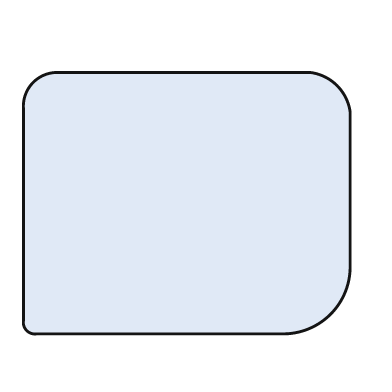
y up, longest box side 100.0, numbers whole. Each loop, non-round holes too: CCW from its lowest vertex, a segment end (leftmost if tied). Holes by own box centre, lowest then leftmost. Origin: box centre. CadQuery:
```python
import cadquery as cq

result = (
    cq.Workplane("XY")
    .moveTo(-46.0, -40.0)
    .lineTo(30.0, -40.0)
    .threePointArc((44.0, -34.0), (50.0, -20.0))
    .lineTo(50.0, 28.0)
    .threePointArc((46.0, 36.0), (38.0, 40.0))
    .lineTo(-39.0, 40.0)
    .threePointArc((-47.0, 37.0), (-50.0, 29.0))
    .lineTo(-50.0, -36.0)
    .threePointArc((-49.0, -39.0), (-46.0, -40.0))
    .close()
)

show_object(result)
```